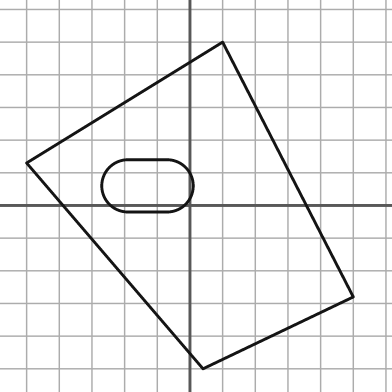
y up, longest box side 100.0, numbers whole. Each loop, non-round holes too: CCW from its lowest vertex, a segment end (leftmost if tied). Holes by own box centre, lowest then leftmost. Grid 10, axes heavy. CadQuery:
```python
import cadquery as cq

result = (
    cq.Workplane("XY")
    .moveTo(4.0, -50.0)
    .lineTo(50.0, -28.0)
    .lineTo(10.0, 50.0)
    .lineTo(-50.0, 13.0)
    .close()
    .moveTo(-19.0, -2.0)
    .lineTo(-7.0, -2.0)
    .threePointArc((1.0, 6.0), (-7.0, 14.0))
    .lineTo(-19.0, 14.0)
    .threePointArc((-27.0, 6.0), (-19.0, -2.0))
    .close()
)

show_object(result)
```